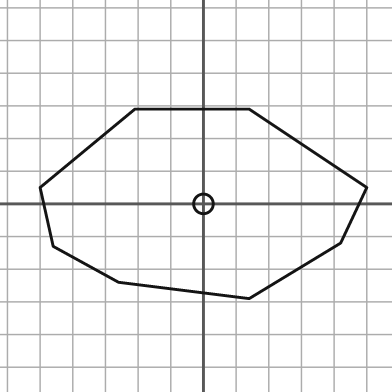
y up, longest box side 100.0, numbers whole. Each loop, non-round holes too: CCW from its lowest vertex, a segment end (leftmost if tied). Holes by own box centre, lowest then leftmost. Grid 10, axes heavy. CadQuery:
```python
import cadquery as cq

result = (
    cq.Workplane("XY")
    .moveTo(14.0, -29.0)
    .lineTo(42.0, -12.0)
    .lineTo(50.0, 5.0)
    .lineTo(14.0, 29.0)
    .lineTo(-21.0, 29.0)
    .lineTo(-50.0, 5.0)
    .lineTo(-46.0, -13.0)
    .lineTo(-26.0, -24.0)
    .close()
    .moveTo(0.0, 0.0)
    .circle(3.0)
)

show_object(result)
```